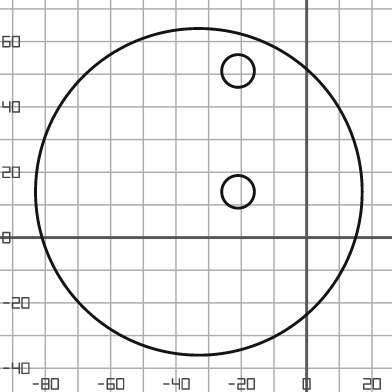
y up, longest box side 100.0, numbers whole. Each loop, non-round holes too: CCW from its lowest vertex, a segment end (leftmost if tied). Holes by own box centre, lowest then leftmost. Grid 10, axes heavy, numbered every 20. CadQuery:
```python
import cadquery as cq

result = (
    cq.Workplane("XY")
    .moveTo(-33.0, 14.0)
    .circle(50.0)
    .moveTo(-21.0, 14.0)
    .circle(5.0)
    .moveTo(-21.0, 51.0)
    .circle(5.0)
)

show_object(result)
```